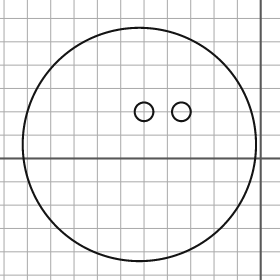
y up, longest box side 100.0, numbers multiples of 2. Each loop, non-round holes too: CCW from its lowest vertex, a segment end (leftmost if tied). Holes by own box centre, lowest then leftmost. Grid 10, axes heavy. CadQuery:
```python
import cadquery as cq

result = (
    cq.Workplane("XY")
    .moveTo(-52.0, 6.0)
    .circle(50.0)
    .moveTo(-50.0, 20.0)
    .circle(4.0)
    .moveTo(-34.0, 20.0)
    .circle(4.0)
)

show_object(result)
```